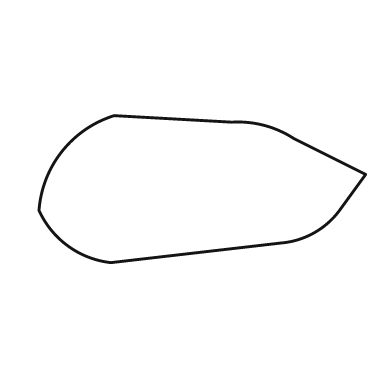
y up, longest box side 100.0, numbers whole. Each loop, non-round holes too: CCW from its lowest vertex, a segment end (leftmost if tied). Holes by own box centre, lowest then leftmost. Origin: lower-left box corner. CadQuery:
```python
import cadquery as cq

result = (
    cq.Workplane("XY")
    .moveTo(22.0, 0.0)
    .lineTo(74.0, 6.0)
    .threePointArc((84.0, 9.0), (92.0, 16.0))
    .lineTo(100.0, 27.0)
    .lineTo(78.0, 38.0)
    .threePointArc((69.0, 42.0), (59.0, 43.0))
    .lineTo(23.0, 45.0)
    .threePointArc((7.0, 34.0), (0.0, 16.0))
    .threePointArc((9.0, 5.0), (22.0, 0.0))
    .close()
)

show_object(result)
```